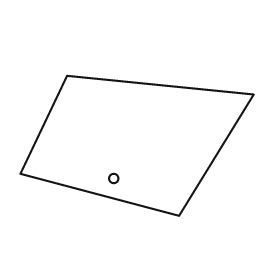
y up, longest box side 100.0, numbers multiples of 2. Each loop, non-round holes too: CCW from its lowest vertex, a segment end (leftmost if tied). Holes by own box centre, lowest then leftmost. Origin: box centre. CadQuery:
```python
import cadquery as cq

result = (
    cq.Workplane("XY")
    .moveTo(18.0, -30.0)
    .lineTo(50.0, 22.0)
    .lineTo(-30.0, 30.0)
    .lineTo(-50.0, -12.0)
    .close()
    .moveTo(-10.0, -14.0)
    .circle(2.0)
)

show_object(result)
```